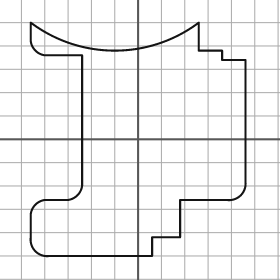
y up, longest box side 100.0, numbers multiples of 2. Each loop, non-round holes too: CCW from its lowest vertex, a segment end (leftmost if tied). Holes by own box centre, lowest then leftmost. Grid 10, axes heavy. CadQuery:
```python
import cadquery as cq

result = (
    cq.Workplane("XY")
    .moveTo(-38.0, -50.0)
    .lineTo(6.0, -50.0)
    .lineTo(6.0, -42.0)
    .lineTo(18.0, -42.0)
    .lineTo(18.0, -26.0)
    .lineTo(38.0, -26.0)
    .threePointArc((44.0, -24.0), (46.0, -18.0))
    .lineTo(46.0, 34.0)
    .lineTo(36.0, 34.0)
    .lineTo(36.0, 38.0)
    .lineTo(26.0, 38.0)
    .lineTo(26.0, 50.0)
    .threePointArc((-10.0, 38.0), (-46.0, 50.0))
    .lineTo(-46.0, 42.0)
    .threePointArc((-44.0, 38.0), (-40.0, 36.0))
    .lineTo(-24.0, 36.0)
    .lineTo(-24.0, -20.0)
    .threePointArc((-26.0, -24.0), (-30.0, -26.0))
    .lineTo(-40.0, -26.0)
    .threePointArc((-44.0, -28.0), (-46.0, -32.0))
    .lineTo(-46.0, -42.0)
    .threePointArc((-44.0, -48.0), (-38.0, -50.0))
    .close()
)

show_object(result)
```